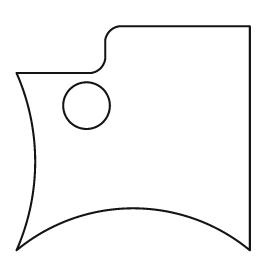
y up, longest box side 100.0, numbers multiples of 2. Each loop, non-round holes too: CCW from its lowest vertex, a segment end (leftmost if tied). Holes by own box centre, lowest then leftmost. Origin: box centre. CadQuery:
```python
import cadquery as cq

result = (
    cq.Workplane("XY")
    .moveTo(-50.0, -48.0)
    .threePointArc((0.0, -30.0), (50.0, -48.0))
    .lineTo(50.0, 48.0)
    .lineTo(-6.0, 48.0)
    .threePointArc((-10.0, 46.0), (-12.0, 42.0))
    .lineTo(-12.0, 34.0)
    .threePointArc((-14.0, 30.0), (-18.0, 28.0))
    .lineTo(-50.0, 28.0)
    .threePointArc((-42.0, -10.0), (-50.0, -48.0))
    .close()
    .moveTo(-20.0, 14.0)
    .circle(10.0)
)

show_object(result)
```